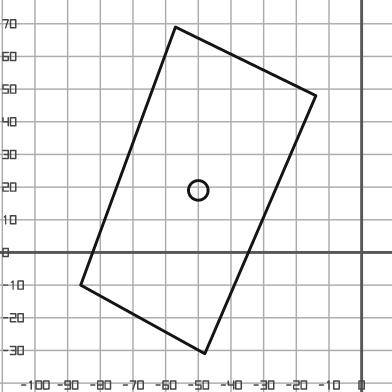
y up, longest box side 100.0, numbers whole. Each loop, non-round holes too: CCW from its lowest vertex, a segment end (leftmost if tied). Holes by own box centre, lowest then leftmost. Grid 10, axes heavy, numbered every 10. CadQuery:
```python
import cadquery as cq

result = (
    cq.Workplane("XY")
    .moveTo(-48.0, -31.0)
    .lineTo(-14.0, 48.0)
    .lineTo(-57.0, 69.0)
    .lineTo(-86.0, -10.0)
    .close()
    .moveTo(-50.0, 19.0)
    .circle(3.0)
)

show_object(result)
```